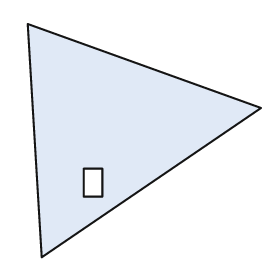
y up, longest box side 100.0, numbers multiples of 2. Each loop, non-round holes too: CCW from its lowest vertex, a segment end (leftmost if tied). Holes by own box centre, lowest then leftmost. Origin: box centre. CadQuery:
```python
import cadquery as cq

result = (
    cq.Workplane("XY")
    .moveTo(-44.0, -50.0)
    .lineTo(50.0, 14.0)
    .lineTo(-50.0, 50.0)
    .close()
    .moveTo(-26.0, -24.0)
    .lineTo(-18.0, -24.0)
    .lineTo(-18.0, -12.0)
    .lineTo(-26.0, -12.0)
    .close()
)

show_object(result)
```